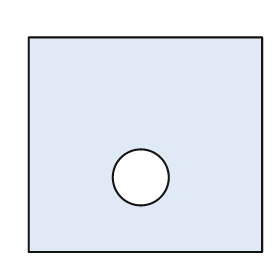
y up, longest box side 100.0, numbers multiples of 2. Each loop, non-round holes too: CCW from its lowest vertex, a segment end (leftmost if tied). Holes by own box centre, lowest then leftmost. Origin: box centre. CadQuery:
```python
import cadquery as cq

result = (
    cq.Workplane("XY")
    .moveTo(-50.0, -46.0)
    .lineTo(50.0, -46.0)
    .lineTo(50.0, 46.0)
    .lineTo(-50.0, 46.0)
    .close()
    .moveTo(-2.0, -14.0)
    .circle(12.0)
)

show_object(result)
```